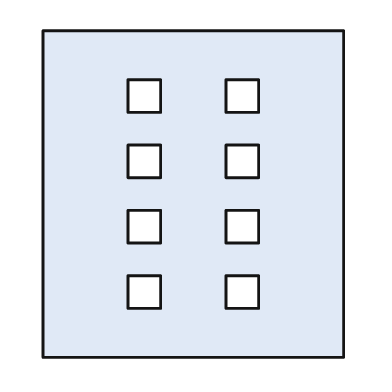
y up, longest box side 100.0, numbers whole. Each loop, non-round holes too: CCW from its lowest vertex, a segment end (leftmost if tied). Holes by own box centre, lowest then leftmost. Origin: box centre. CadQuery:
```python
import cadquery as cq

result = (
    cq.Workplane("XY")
    .moveTo(-46.0, -50.0)
    .lineTo(46.0, -50.0)
    .lineTo(46.0, 50.0)
    .lineTo(-46.0, 50.0)
    .close()
    .moveTo(-20.0, -35.0)
    .lineTo(-10.0, -35.0)
    .lineTo(-10.0, -25.0)
    .lineTo(-20.0, -25.0)
    .close()
    .moveTo(10.0, -35.0)
    .lineTo(20.0, -35.0)
    .lineTo(20.0, -25.0)
    .lineTo(10.0, -25.0)
    .close()
    .moveTo(-20.0, -15.0)
    .lineTo(-10.0, -15.0)
    .lineTo(-10.0, -5.0)
    .lineTo(-20.0, -5.0)
    .close()
    .moveTo(10.0, -15.0)
    .lineTo(20.0, -15.0)
    .lineTo(20.0, -5.0)
    .lineTo(10.0, -5.0)
    .close()
    .moveTo(-20.0, 5.0)
    .lineTo(-10.0, 5.0)
    .lineTo(-10.0, 15.0)
    .lineTo(-20.0, 15.0)
    .close()
    .moveTo(10.0, 5.0)
    .lineTo(20.0, 5.0)
    .lineTo(20.0, 15.0)
    .lineTo(10.0, 15.0)
    .close()
    .moveTo(-20.0, 25.0)
    .lineTo(-10.0, 25.0)
    .lineTo(-10.0, 35.0)
    .lineTo(-20.0, 35.0)
    .close()
    .moveTo(10.0, 25.0)
    .lineTo(20.0, 25.0)
    .lineTo(20.0, 35.0)
    .lineTo(10.0, 35.0)
    .close()
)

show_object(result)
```